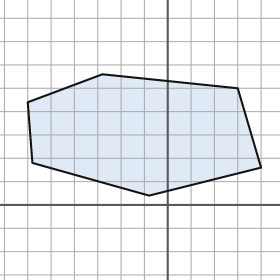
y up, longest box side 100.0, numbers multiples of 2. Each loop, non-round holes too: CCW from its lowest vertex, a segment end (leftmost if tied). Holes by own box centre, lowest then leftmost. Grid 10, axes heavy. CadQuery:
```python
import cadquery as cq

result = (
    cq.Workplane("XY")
    .moveTo(-8.0, 4.0)
    .lineTo(40.0, 16.0)
    .lineTo(30.0, 50.0)
    .lineTo(-28.0, 56.0)
    .lineTo(-60.0, 44.0)
    .lineTo(-58.0, 18.0)
    .close()
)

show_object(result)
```